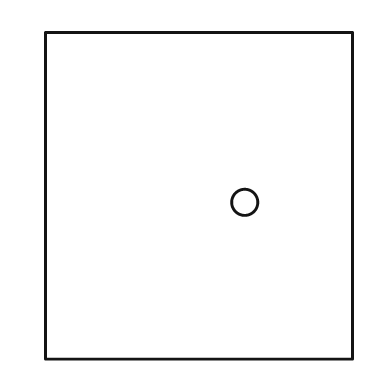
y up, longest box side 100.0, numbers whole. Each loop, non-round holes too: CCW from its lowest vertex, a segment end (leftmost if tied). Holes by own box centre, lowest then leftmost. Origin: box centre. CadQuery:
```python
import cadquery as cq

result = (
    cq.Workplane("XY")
    .moveTo(-47.0, -50.0)
    .lineTo(47.0, -50.0)
    .lineTo(47.0, 50.0)
    .lineTo(-47.0, 50.0)
    .close()
    .moveTo(14.0, -2.0)
    .circle(4.0)
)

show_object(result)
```